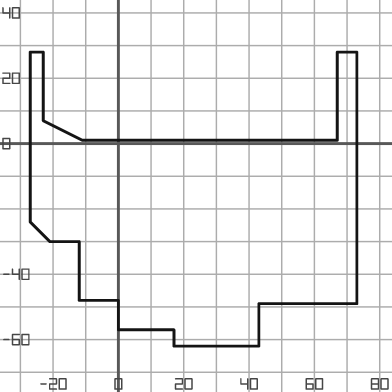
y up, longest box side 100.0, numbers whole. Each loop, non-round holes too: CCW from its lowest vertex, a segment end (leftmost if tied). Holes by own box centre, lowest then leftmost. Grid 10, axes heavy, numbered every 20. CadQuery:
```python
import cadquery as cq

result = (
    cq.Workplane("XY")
    .moveTo(17.0, -62.0)
    .lineTo(43.0, -62.0)
    .lineTo(43.0, -49.0)
    .lineTo(73.0, -49.0)
    .lineTo(73.0, 28.0)
    .lineTo(67.0, 28.0)
    .lineTo(67.0, 1.0)
    .lineTo(-11.0, 1.0)
    .lineTo(-23.0, 7.0)
    .lineTo(-23.0, 28.0)
    .lineTo(-27.0, 28.0)
    .lineTo(-27.0, -24.0)
    .lineTo(-21.0, -30.0)
    .lineTo(-12.0, -30.0)
    .lineTo(-12.0, -48.0)
    .lineTo(0.0, -48.0)
    .lineTo(0.0, -57.0)
    .lineTo(17.0, -57.0)
    .close()
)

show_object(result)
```